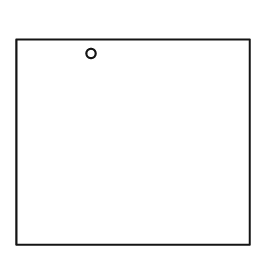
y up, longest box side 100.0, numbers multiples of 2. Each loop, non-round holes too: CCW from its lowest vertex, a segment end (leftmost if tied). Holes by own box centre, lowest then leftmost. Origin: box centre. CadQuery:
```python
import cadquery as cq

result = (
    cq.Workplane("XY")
    .moveTo(-50.0, -44.0)
    .lineTo(50.0, -44.0)
    .lineTo(50.0, 44.0)
    .lineTo(-50.0, 44.0)
    .close()
    .moveTo(-18.0, 38.0)
    .circle(2.0)
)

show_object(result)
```